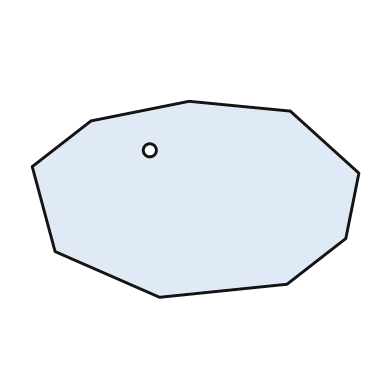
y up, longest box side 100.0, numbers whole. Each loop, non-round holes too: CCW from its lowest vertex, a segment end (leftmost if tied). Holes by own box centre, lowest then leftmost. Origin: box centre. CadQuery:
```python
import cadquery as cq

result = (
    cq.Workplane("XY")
    .moveTo(-11.0, -30.0)
    .lineTo(28.0, -26.0)
    .lineTo(46.0, -12.0)
    .lineTo(50.0, 8.0)
    .lineTo(29.0, 27.0)
    .lineTo(-2.0, 30.0)
    .lineTo(-32.0, 24.0)
    .lineTo(-50.0, 10.0)
    .lineTo(-43.0, -16.0)
    .close()
    .moveTo(-14.0, 15.0)
    .circle(2.0)
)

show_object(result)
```